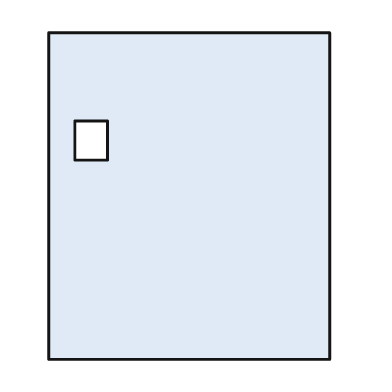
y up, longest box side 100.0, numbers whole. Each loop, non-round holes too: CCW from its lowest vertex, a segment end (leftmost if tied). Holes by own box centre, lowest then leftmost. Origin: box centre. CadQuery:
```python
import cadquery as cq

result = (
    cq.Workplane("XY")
    .moveTo(-43.0, -50.0)
    .lineTo(43.0, -50.0)
    .lineTo(43.0, 50.0)
    .lineTo(-43.0, 50.0)
    .close()
    .moveTo(-35.0, 11.0)
    .lineTo(-25.0, 11.0)
    .lineTo(-25.0, 23.0)
    .lineTo(-35.0, 23.0)
    .close()
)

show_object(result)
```